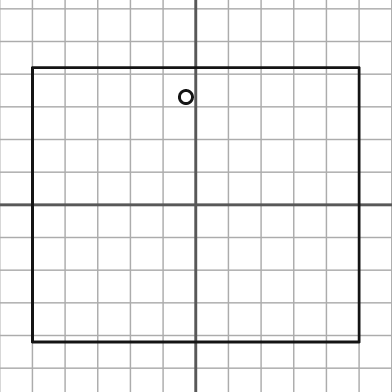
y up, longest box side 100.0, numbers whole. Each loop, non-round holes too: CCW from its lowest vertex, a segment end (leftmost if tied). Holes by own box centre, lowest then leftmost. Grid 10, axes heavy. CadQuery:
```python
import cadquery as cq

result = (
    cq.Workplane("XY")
    .moveTo(-50.0, -42.0)
    .lineTo(50.0, -42.0)
    .lineTo(50.0, 42.0)
    .lineTo(-50.0, 42.0)
    .close()
    .moveTo(-3.0, 33.0)
    .circle(2.0)
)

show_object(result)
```